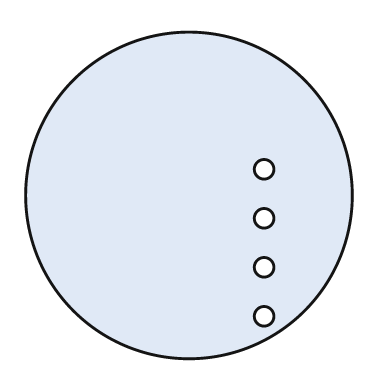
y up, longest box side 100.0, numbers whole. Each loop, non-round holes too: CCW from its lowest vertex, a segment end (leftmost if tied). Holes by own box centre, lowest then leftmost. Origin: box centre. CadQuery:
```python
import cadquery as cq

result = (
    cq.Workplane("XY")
    .moveTo(0.0, 0.0)
    .circle(50.0)
    .moveTo(23.0, -37.0)
    .circle(3.0)
    .moveTo(23.0, -22.0)
    .circle(3.0)
    .moveTo(23.0, -7.0)
    .circle(3.0)
    .moveTo(23.0, 8.0)
    .circle(3.0)
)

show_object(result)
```